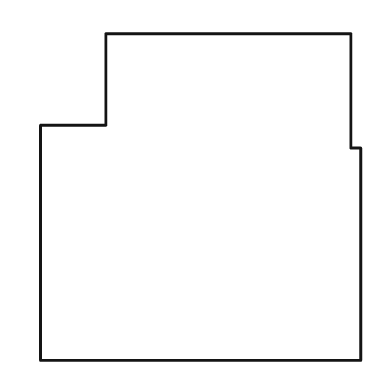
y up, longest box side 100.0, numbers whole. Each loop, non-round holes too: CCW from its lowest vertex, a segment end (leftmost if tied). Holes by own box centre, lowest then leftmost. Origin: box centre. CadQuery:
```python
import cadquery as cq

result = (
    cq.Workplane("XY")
    .moveTo(-49.0, -50.0)
    .lineTo(49.0, -50.0)
    .lineTo(49.0, 15.0)
    .lineTo(46.0, 15.0)
    .lineTo(46.0, 50.0)
    .lineTo(-29.0, 50.0)
    .lineTo(-29.0, 22.0)
    .lineTo(-49.0, 22.0)
    .close()
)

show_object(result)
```